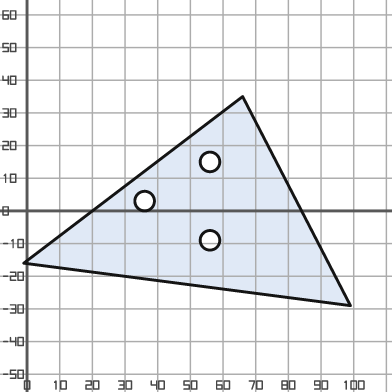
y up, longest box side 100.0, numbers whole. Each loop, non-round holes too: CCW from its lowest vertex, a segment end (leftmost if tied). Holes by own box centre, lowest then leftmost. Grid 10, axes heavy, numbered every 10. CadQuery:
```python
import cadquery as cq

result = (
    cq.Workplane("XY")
    .moveTo(99.0, -29.0)
    .lineTo(66.0, 35.0)
    .lineTo(-1.0, -16.0)
    .close()
    .moveTo(56.0, -9.0)
    .circle(3.0)
    .moveTo(36.0, 3.0)
    .circle(3.0)
    .moveTo(56.0, 15.0)
    .circle(3.0)
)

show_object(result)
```